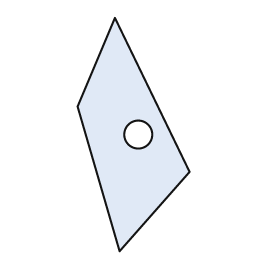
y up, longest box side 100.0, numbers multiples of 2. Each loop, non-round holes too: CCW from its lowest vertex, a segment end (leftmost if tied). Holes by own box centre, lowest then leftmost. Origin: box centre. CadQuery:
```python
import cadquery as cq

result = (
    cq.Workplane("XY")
    .moveTo(-6.0, -50.0)
    .lineTo(24.0, -16.0)
    .lineTo(-8.0, 50.0)
    .lineTo(-24.0, 12.0)
    .close()
    .moveTo(2.0, 0.0)
    .circle(6.0)
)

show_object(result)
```